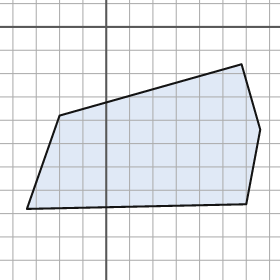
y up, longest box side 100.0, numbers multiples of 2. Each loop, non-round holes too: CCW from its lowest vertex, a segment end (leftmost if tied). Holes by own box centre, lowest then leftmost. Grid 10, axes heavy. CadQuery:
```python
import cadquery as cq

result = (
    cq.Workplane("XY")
    .moveTo(-34.0, -78.0)
    .lineTo(60.0, -76.0)
    .lineTo(66.0, -44.0)
    .lineTo(58.0, -16.0)
    .lineTo(-20.0, -38.0)
    .close()
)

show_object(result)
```